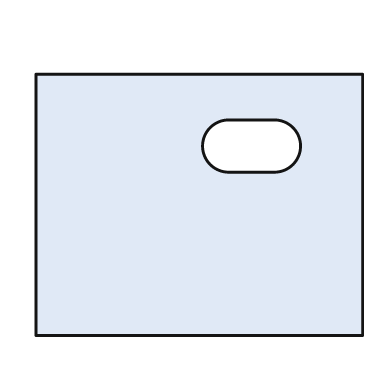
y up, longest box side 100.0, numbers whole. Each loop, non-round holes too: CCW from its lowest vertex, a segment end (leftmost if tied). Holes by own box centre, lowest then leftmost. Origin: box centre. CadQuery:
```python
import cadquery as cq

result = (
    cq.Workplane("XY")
    .moveTo(-50.0, -40.0)
    .lineTo(50.0, -40.0)
    .lineTo(50.0, 40.0)
    .lineTo(-50.0, 40.0)
    .close()
    .moveTo(9.0, 10.0)
    .lineTo(23.0, 10.0)
    .threePointArc((31.0, 18.0), (23.0, 26.0))
    .lineTo(9.0, 26.0)
    .threePointArc((1.0, 18.0), (9.0, 10.0))
    .close()
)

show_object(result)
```